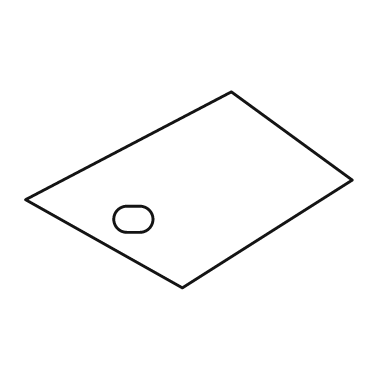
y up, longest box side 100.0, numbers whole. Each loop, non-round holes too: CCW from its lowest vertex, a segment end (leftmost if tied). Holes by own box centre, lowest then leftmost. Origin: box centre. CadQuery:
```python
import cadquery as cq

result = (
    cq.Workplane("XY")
    .moveTo(-2.0, -30.0)
    .lineTo(50.0, 3.0)
    .lineTo(13.0, 30.0)
    .lineTo(-50.0, -3.0)
    .close()
    .moveTo(-19.0, -13.0)
    .lineTo(-15.0, -13.0)
    .threePointArc((-11.0, -9.0), (-15.0, -5.0))
    .lineTo(-19.0, -5.0)
    .threePointArc((-23.0, -9.0), (-19.0, -13.0))
    .close()
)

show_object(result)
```